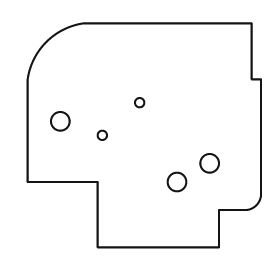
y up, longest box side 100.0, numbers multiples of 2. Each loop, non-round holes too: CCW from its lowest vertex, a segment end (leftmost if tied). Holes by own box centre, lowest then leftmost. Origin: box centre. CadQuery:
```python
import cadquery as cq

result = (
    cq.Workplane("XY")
    .moveTo(-20.0, -48.0)
    .lineTo(32.0, -48.0)
    .lineTo(32.0, -32.0)
    .lineTo(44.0, -32.0)
    .threePointArc((48.0, -30.0), (50.0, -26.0))
    .lineTo(50.0, 24.0)
    .lineTo(46.0, 24.0)
    .lineTo(46.0, 48.0)
    .lineTo(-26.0, 48.0)
    .threePointArc((-42.0, 40.0), (-50.0, 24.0))
    .lineTo(-50.0, -20.0)
    .lineTo(-20.0, -20.0)
    .close()
    .moveTo(14.0, -20.0)
    .circle(4.0)
    .moveTo(28.0, -12.0)
    .circle(4.0)
    .moveTo(-18.0, 0.0)
    .circle(2.0)
    .moveTo(-36.0, 6.0)
    .circle(4.0)
    .moveTo(-2.0, 14.0)
    .circle(2.0)
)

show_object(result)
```